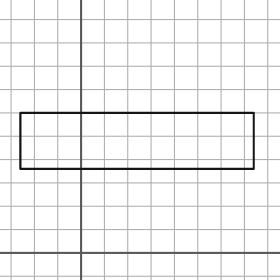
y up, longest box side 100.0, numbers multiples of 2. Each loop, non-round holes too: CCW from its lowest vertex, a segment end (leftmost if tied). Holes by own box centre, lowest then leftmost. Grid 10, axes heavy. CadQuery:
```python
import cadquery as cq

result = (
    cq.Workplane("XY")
    .moveTo(-26.0, 36.0)
    .lineTo(74.0, 36.0)
    .lineTo(74.0, 60.0)
    .lineTo(-26.0, 60.0)
    .close()
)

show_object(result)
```